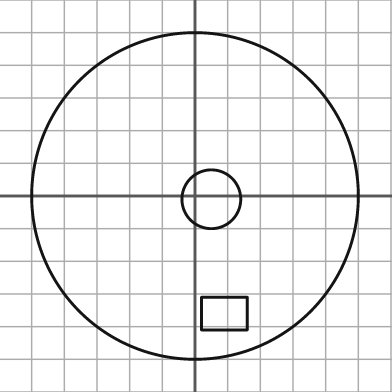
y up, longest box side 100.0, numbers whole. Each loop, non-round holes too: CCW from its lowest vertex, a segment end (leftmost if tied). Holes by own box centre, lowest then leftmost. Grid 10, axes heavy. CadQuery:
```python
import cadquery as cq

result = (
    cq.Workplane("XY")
    .moveTo(0.0, 0.0)
    .circle(50.0)
    .moveTo(2.0, -41.0)
    .lineTo(16.0, -41.0)
    .lineTo(16.0, -31.0)
    .lineTo(2.0, -31.0)
    .close()
    .moveTo(5.0, -1.0)
    .circle(9.0)
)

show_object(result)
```